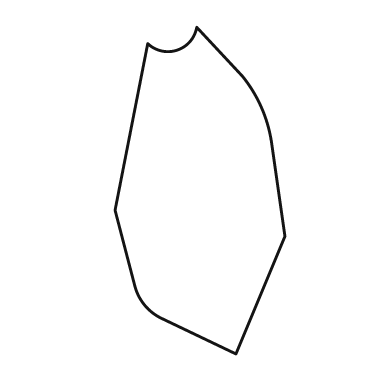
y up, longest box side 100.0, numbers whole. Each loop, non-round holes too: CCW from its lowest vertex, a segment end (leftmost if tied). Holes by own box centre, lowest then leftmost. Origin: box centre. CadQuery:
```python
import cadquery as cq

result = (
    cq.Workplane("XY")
    .moveTo(11.0, -50.0)
    .lineTo(26.0, -14.0)
    .lineTo(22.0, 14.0)
    .threePointArc((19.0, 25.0), (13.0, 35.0))
    .lineTo(-1.0, 50.0)
    .threePointArc((-7.0, 43.0), (-16.0, 45.0))
    .lineTo(-26.0, -6.0)
    .lineTo(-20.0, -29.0)
    .threePointArc((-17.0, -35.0), (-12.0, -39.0))
    .close()
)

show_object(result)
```